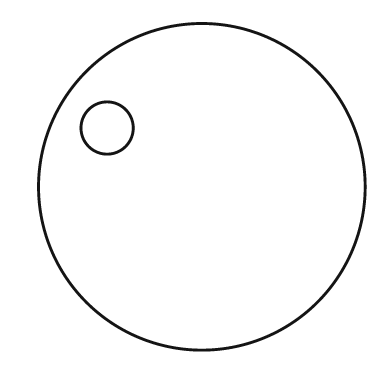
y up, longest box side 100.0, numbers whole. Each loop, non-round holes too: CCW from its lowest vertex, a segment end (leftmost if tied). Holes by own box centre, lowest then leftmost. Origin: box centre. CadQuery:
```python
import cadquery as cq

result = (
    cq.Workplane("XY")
    .moveTo(0.0, 0.0)
    .circle(50.0)
    .moveTo(-29.0, 18.0)
    .circle(8.0)
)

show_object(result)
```